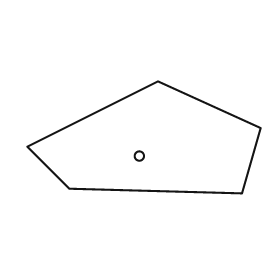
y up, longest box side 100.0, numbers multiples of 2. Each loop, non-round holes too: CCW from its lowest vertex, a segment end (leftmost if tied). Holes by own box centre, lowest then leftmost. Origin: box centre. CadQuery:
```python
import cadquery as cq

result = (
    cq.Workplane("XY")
    .moveTo(42.0, -24.0)
    .lineTo(50.0, 4.0)
    .lineTo(6.0, 24.0)
    .lineTo(-50.0, -4.0)
    .lineTo(-32.0, -22.0)
    .close()
    .moveTo(-2.0, -8.0)
    .circle(2.0)
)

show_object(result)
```